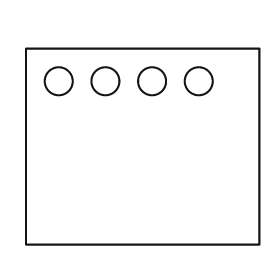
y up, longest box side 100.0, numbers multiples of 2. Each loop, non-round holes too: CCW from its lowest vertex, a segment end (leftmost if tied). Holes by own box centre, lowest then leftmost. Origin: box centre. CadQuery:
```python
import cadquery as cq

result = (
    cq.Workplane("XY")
    .moveTo(-50.0, -42.0)
    .lineTo(50.0, -42.0)
    .lineTo(50.0, 42.0)
    .lineTo(-50.0, 42.0)
    .close()
    .moveTo(-36.0, 28.0)
    .circle(6.0)
    .moveTo(-16.0, 28.0)
    .circle(6.0)
    .moveTo(4.0, 28.0)
    .circle(6.0)
    .moveTo(24.0, 28.0)
    .circle(6.0)
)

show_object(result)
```